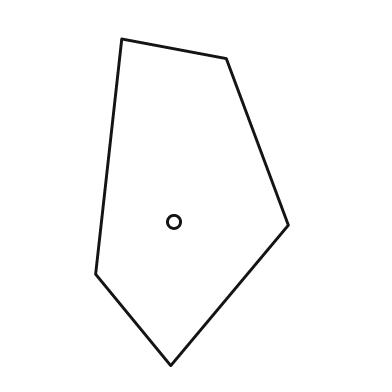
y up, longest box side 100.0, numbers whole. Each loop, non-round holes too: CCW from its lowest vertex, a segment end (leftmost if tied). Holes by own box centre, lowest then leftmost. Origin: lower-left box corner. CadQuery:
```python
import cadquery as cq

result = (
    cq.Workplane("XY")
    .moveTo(23.0, 0.0)
    .lineTo(59.0, 43.0)
    .lineTo(40.0, 94.0)
    .lineTo(8.0, 100.0)
    .lineTo(0.0, 28.0)
    .close()
    .moveTo(24.0, 44.0)
    .circle(2.0)
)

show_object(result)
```